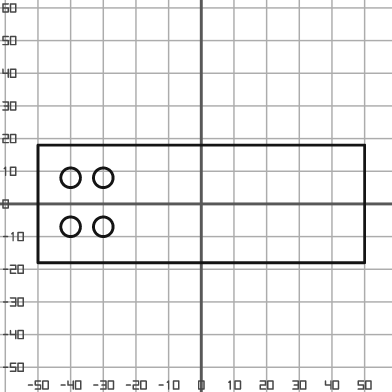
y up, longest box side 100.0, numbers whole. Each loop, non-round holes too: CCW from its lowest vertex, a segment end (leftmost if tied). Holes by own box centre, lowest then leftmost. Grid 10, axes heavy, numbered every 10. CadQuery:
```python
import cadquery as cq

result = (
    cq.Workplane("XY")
    .moveTo(-50.0, -18.0)
    .lineTo(50.0, -18.0)
    .lineTo(50.0, 18.0)
    .lineTo(-50.0, 18.0)
    .close()
    .moveTo(-40.0, -7.0)
    .circle(3.0)
    .moveTo(-30.0, -7.0)
    .circle(3.0)
    .moveTo(-40.0, 8.0)
    .circle(3.0)
    .moveTo(-30.0, 8.0)
    .circle(3.0)
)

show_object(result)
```